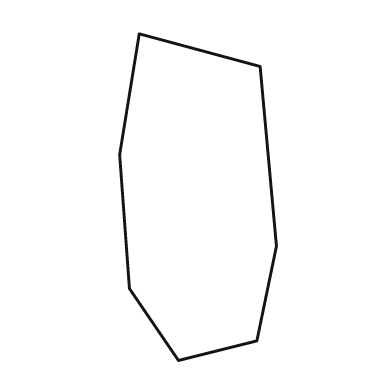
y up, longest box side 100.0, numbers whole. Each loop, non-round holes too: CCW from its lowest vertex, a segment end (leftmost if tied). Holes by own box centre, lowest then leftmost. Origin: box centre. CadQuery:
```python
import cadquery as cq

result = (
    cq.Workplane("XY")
    .moveTo(-6.0, -50.0)
    .lineTo(18.0, -44.0)
    .lineTo(24.0, -15.0)
    .lineTo(19.0, 40.0)
    .lineTo(-18.0, 50.0)
    .lineTo(-24.0, 13.0)
    .lineTo(-21.0, -28.0)
    .close()
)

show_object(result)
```